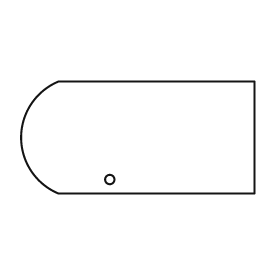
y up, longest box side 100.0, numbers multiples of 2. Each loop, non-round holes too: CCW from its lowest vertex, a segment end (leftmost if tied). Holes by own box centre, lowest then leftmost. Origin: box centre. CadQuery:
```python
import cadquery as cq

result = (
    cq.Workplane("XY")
    .moveTo(-34.0, -24.0)
    .lineTo(50.0, -24.0)
    .lineTo(50.0, 24.0)
    .lineTo(-34.0, 24.0)
    .threePointArc((-50.0, 0.0), (-34.0, -24.0))
    .close()
    .moveTo(-12.0, -18.0)
    .circle(2.0)
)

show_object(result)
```